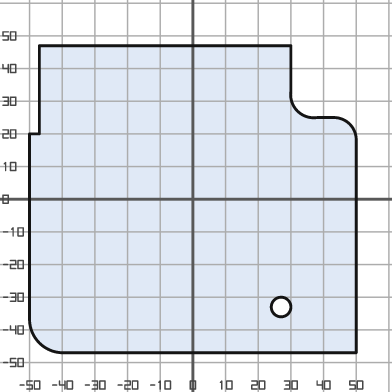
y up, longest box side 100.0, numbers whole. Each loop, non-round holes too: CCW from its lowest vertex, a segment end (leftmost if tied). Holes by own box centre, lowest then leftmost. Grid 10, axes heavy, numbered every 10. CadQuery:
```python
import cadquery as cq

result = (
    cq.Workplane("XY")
    .moveTo(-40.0, -47.0)
    .lineTo(50.0, -47.0)
    .lineTo(50.0, 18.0)
    .threePointArc((48.0, 23.0), (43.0, 25.0))
    .lineTo(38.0, 25.0)
    .threePointArc((32.0, 27.0), (30.0, 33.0))
    .lineTo(30.0, 47.0)
    .lineTo(-47.0, 47.0)
    .lineTo(-47.0, 20.0)
    .lineTo(-50.0, 20.0)
    .lineTo(-50.0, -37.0)
    .threePointArc((-47.0, -44.0), (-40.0, -47.0))
    .close()
    .moveTo(27.0, -33.0)
    .circle(3.0)
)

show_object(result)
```